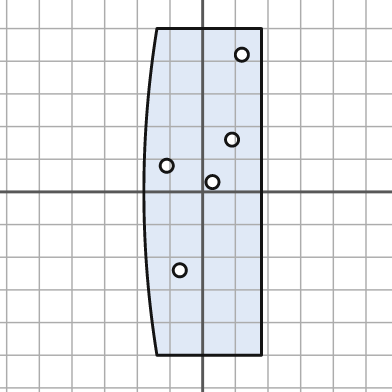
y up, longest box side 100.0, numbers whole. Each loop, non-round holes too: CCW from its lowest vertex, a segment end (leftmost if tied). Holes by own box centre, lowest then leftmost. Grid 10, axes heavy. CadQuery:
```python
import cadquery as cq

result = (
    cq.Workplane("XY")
    .moveTo(-14.0, -50.0)
    .lineTo(18.0, -50.0)
    .lineTo(18.0, 50.0)
    .lineTo(-14.0, 50.0)
    .threePointArc((-18.0, 0.0), (-14.0, -50.0))
    .close()
    .moveTo(-7.0, -24.0)
    .circle(2.0)
    .moveTo(3.0, 3.0)
    .circle(2.0)
    .moveTo(-11.0, 8.0)
    .circle(2.0)
    .moveTo(9.0, 16.0)
    .circle(2.0)
    .moveTo(12.0, 42.0)
    .circle(2.0)
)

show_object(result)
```